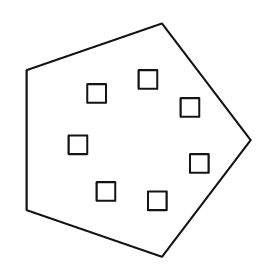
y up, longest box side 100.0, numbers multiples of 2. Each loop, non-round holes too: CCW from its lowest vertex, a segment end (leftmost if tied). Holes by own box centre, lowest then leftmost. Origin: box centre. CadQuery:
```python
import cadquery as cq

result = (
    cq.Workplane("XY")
    .moveTo(10.0, -50.0)
    .lineTo(48.0, 0.0)
    .lineTo(10.0, 50.0)
    .lineTo(-48.0, 30.0)
    .lineTo(-48.0, -30.0)
    .close()
    .moveTo(4.0, -30.0)
    .lineTo(12.0, -30.0)
    .lineTo(12.0, -22.0)
    .lineTo(4.0, -22.0)
    .close()
    .moveTo(-18.0, -26.0)
    .lineTo(-10.0, -26.0)
    .lineTo(-10.0, -18.0)
    .lineTo(-18.0, -18.0)
    .close()
    .moveTo(22.0, -14.0)
    .lineTo(30.0, -14.0)
    .lineTo(30.0, -6.0)
    .lineTo(22.0, -6.0)
    .close()
    .moveTo(-30.0, -6.0)
    .lineTo(-22.0, -6.0)
    .lineTo(-22.0, 2.0)
    .lineTo(-30.0, 2.0)
    .close()
    .moveTo(18.0, 10.0)
    .lineTo(26.0, 10.0)
    .lineTo(26.0, 18.0)
    .lineTo(18.0, 18.0)
    .close()
    .moveTo(-22.0, 16.0)
    .lineTo(-14.0, 16.0)
    .lineTo(-14.0, 24.0)
    .lineTo(-22.0, 24.0)
    .close()
    .moveTo(0.0, 22.0)
    .lineTo(8.0, 22.0)
    .lineTo(8.0, 30.0)
    .lineTo(0.0, 30.0)
    .close()
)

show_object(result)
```